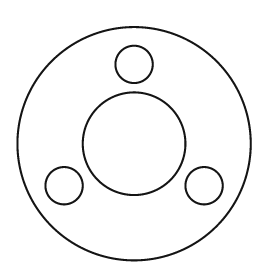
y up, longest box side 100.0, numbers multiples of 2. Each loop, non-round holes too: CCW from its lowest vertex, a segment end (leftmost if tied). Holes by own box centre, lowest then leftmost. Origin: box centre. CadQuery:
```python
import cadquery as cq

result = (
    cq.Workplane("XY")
    .moveTo(0.0, 0.0)
    .circle(50.0)
    .moveTo(-30.0, -18.0)
    .circle(8.0)
    .moveTo(30.0, -18.0)
    .circle(8.0)
    .moveTo(0.0, 0.0)
    .circle(22.0)
    .moveTo(0.0, 34.0)
    .circle(8.0)
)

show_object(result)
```